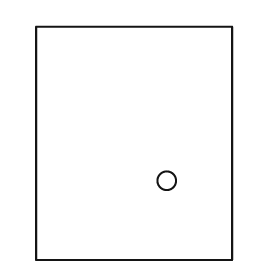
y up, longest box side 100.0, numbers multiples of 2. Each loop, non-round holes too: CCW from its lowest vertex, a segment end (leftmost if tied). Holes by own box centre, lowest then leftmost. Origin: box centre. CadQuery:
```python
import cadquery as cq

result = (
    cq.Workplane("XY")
    .moveTo(-42.0, -50.0)
    .lineTo(42.0, -50.0)
    .lineTo(42.0, 50.0)
    .lineTo(-42.0, 50.0)
    .close()
    .moveTo(14.0, -16.0)
    .circle(4.0)
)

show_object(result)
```